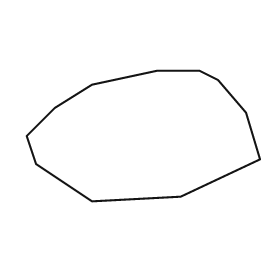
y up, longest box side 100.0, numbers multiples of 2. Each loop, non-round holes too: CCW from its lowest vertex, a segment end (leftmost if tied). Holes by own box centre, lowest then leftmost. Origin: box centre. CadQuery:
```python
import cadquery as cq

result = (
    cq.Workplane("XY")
    .moveTo(-22.0, -28.0)
    .lineTo(16.0, -26.0)
    .lineTo(50.0, -10.0)
    .lineTo(44.0, 10.0)
    .lineTo(32.0, 24.0)
    .lineTo(24.0, 28.0)
    .lineTo(6.0, 28.0)
    .lineTo(-22.0, 22.0)
    .lineTo(-38.0, 12.0)
    .lineTo(-50.0, 0.0)
    .lineTo(-46.0, -12.0)
    .close()
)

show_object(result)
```